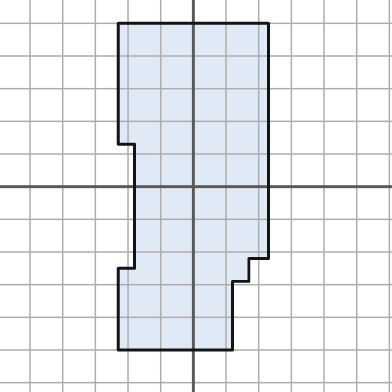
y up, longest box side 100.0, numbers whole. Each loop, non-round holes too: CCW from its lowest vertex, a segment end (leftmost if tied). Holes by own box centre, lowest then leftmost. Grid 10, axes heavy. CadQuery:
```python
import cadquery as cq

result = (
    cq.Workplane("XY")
    .moveTo(-23.0, -50.0)
    .lineTo(12.0, -50.0)
    .lineTo(12.0, -29.0)
    .lineTo(17.0, -29.0)
    .lineTo(17.0, -22.0)
    .lineTo(23.0, -22.0)
    .lineTo(23.0, 50.0)
    .lineTo(-23.0, 50.0)
    .lineTo(-23.0, 13.0)
    .lineTo(-18.0, 13.0)
    .lineTo(-18.0, -25.0)
    .lineTo(-23.0, -25.0)
    .close()
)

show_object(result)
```